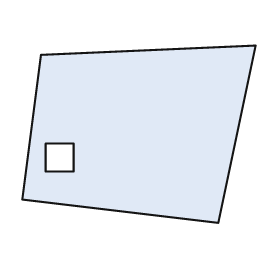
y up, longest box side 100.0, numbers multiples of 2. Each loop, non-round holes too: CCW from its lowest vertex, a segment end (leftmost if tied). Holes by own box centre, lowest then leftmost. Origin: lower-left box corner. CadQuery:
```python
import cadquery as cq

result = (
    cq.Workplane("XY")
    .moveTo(84.0, 0.0)
    .lineTo(100.0, 76.0)
    .lineTo(8.0, 72.0)
    .lineTo(0.0, 10.0)
    .close()
    .moveTo(10.0, 22.0)
    .lineTo(22.0, 22.0)
    .lineTo(22.0, 34.0)
    .lineTo(10.0, 34.0)
    .close()
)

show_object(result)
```